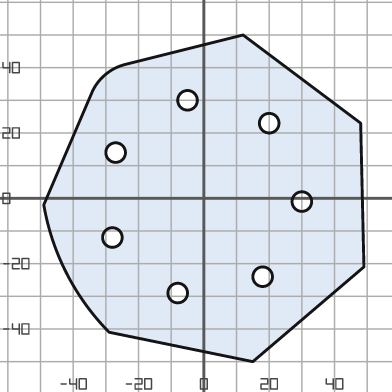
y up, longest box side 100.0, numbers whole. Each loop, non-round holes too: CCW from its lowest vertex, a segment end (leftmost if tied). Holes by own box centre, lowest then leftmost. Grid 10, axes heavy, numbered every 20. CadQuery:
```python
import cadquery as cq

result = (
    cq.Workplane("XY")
    .moveTo(15.0, -50.0)
    .lineTo(49.0, -21.0)
    .lineTo(48.0, 23.0)
    .lineTo(12.0, 50.0)
    .lineTo(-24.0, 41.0)
    .threePointArc((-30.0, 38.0), (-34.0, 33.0))
    .lineTo(-49.0, -2.0)
    .threePointArc((-42.0, -23.0), (-29.0, -41.0))
    .close()
    .moveTo(-8.0, -29.0)
    .circle(3.0)
    .moveTo(18.0, -24.0)
    .circle(3.0)
    .moveTo(-28.0, -12.0)
    .circle(3.0)
    .moveTo(30.0, -1.0)
    .circle(3.0)
    .moveTo(-27.0, 14.0)
    .circle(3.0)
    .moveTo(20.0, 23.0)
    .circle(3.0)
    .moveTo(-5.0, 30.0)
    .circle(3.0)
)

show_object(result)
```